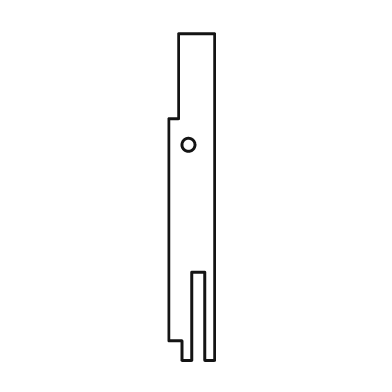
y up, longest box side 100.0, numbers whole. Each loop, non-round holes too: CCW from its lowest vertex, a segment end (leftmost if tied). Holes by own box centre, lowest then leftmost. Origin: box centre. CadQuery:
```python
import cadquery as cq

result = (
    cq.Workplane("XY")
    .moveTo(-3.0, -50.0)
    .lineTo(0.0, -50.0)
    .lineTo(0.0, -23.0)
    .lineTo(4.0, -23.0)
    .lineTo(4.0, -50.0)
    .lineTo(7.0, -50.0)
    .lineTo(7.0, 50.0)
    .lineTo(-4.0, 50.0)
    .lineTo(-4.0, 24.0)
    .lineTo(-7.0, 24.0)
    .lineTo(-7.0, -44.0)
    .lineTo(-3.0, -44.0)
    .close()
    .moveTo(-1.0, 16.0)
    .circle(2.0)
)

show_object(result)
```